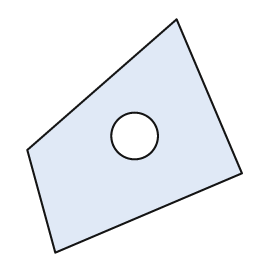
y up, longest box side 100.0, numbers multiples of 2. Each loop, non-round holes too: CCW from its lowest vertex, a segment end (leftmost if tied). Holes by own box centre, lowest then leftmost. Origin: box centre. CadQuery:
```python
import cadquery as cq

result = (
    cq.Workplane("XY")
    .moveTo(-34.0, -50.0)
    .lineTo(46.0, -16.0)
    .lineTo(18.0, 50.0)
    .lineTo(-46.0, -6.0)
    .close()
    .moveTo(0.0, 0.0)
    .circle(10.0)
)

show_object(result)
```